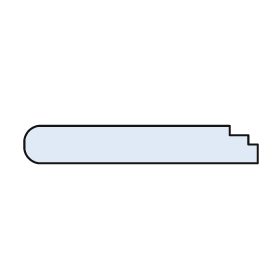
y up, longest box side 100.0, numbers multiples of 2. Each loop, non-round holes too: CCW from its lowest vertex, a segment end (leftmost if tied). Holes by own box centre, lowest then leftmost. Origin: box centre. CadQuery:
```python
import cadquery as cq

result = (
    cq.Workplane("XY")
    .moveTo(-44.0, -8.0)
    .lineTo(50.0, -8.0)
    .lineTo(50.0, 0.0)
    .lineTo(46.0, 0.0)
    .lineTo(46.0, 4.0)
    .lineTo(38.0, 4.0)
    .lineTo(38.0, 8.0)
    .lineTo(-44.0, 8.0)
    .threePointArc((-48.0, 6.0), (-50.0, 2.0))
    .lineTo(-50.0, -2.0)
    .threePointArc((-48.0, -6.0), (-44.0, -8.0))
    .close()
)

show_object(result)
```